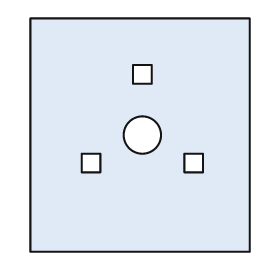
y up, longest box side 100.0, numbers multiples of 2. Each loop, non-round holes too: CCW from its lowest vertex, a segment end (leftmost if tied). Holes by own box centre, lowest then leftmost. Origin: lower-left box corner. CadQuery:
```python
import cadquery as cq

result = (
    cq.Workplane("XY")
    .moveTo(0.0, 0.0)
    .lineTo(94.0, 0.0)
    .lineTo(94.0, 100.0)
    .lineTo(0.0, 100.0)
    .close()
    .moveTo(22.0, 34.0)
    .lineTo(30.0, 34.0)
    .lineTo(30.0, 42.0)
    .lineTo(22.0, 42.0)
    .close()
    .moveTo(66.0, 34.0)
    .lineTo(74.0, 34.0)
    .lineTo(74.0, 42.0)
    .lineTo(66.0, 42.0)
    .close()
    .moveTo(48.0, 50.0)
    .circle(8.0)
    .moveTo(44.0, 72.0)
    .lineTo(52.0, 72.0)
    .lineTo(52.0, 80.0)
    .lineTo(44.0, 80.0)
    .close()
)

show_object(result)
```